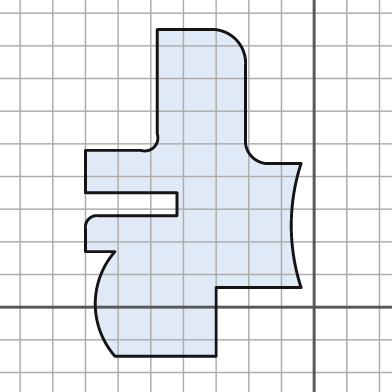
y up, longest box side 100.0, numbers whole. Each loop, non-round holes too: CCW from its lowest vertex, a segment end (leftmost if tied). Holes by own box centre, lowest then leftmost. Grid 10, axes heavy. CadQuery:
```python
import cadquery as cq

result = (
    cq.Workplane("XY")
    .moveTo(-61.0, -15.0)
    .lineTo(-30.0, -15.0)
    .lineTo(-30.0, 6.0)
    .lineTo(-4.0, 6.0)
    .threePointArc((-7.0, 25.0), (-4.0, 44.0))
    .lineTo(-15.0, 44.0)
    .threePointArc((-19.0, 46.0), (-21.0, 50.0))
    .lineTo(-21.0, 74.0)
    .threePointArc((-24.0, 82.0), (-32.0, 85.0))
    .lineTo(-48.0, 85.0)
    .lineTo(-48.0, 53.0)
    .threePointArc((-49.0, 49.0), (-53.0, 48.0))
    .lineTo(-70.0, 48.0)
    .lineTo(-70.0, 35.0)
    .lineTo(-42.0, 35.0)
    .lineTo(-42.0, 28.0)
    .lineTo(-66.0, 28.0)
    .threePointArc((-69.0, 27.0), (-70.0, 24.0))
    .lineTo(-70.0, 17.0)
    .lineTo(-61.0, 17.0)
    .threePointArc((-67.0, 1.0), (-61.0, -15.0))
    .close()
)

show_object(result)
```